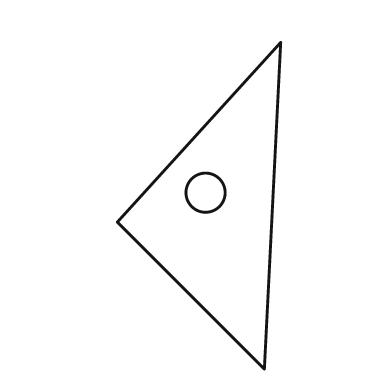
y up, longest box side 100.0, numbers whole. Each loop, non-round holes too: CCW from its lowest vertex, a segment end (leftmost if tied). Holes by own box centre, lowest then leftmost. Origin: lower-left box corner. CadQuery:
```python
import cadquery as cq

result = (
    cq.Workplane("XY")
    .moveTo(45.0, 0.0)
    .lineTo(50.0, 100.0)
    .lineTo(0.0, 45.0)
    .close()
    .moveTo(27.0, 54.0)
    .circle(6.0)
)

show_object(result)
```